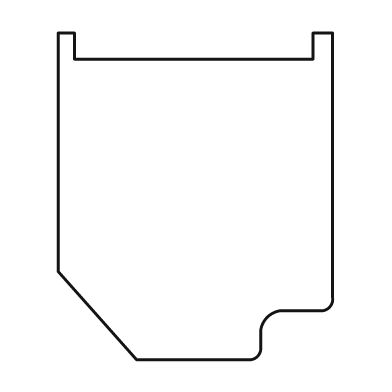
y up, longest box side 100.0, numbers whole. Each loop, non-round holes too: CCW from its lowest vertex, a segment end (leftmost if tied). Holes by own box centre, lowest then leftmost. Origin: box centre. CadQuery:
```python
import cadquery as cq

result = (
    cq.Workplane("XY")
    .moveTo(-18.0, -50.0)
    .lineTo(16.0, -50.0)
    .threePointArc((19.0, -49.0), (20.0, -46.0))
    .lineTo(20.0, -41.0)
    .threePointArc((22.0, -37.0), (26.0, -35.0))
    .lineTo(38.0, -35.0)
    .threePointArc((41.0, -34.0), (42.0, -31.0))
    .lineTo(42.0, 50.0)
    .lineTo(36.0, 50.0)
    .lineTo(36.0, 42.0)
    .lineTo(-37.0, 42.0)
    .lineTo(-37.0, 50.0)
    .lineTo(-42.0, 50.0)
    .lineTo(-42.0, -23.0)
    .close()
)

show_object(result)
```